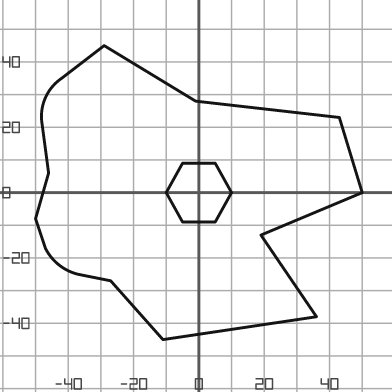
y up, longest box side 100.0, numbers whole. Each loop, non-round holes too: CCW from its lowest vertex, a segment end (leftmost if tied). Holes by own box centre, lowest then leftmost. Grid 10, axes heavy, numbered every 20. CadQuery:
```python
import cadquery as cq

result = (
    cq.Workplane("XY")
    .moveTo(-11.0, -45.0)
    .lineTo(36.0, -38.0)
    .lineTo(19.0, -13.0)
    .lineTo(50.0, 0.0)
    .lineTo(43.0, 23.0)
    .lineTo(-1.0, 28.0)
    .lineTo(-29.0, 45.0)
    .lineTo(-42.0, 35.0)
    .threePointArc((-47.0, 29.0), (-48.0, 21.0))
    .lineTo(-46.0, 6.0)
    .lineTo(-50.0, -8.0)
    .lineTo(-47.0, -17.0)
    .threePointArc((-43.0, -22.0), (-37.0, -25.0))
    .lineTo(-27.0, -27.0)
    .close()
    .moveTo(-5.0, -9.0)
    .lineTo(5.0, -9.0)
    .lineTo(10.0, 0.0)
    .lineTo(5.0, 9.0)
    .lineTo(-5.0, 9.0)
    .lineTo(-10.0, 0.0)
    .close()
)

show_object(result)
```